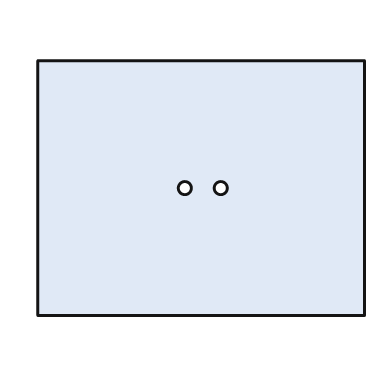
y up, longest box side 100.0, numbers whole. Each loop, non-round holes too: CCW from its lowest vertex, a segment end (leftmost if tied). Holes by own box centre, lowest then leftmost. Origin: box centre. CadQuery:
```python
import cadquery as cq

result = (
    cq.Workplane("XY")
    .moveTo(-50.0, -39.0)
    .lineTo(50.0, -39.0)
    .lineTo(50.0, 39.0)
    .lineTo(-50.0, 39.0)
    .close()
    .moveTo(-5.0, 0.0)
    .circle(2.0)
    .moveTo(6.0, 0.0)
    .circle(2.0)
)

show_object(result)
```